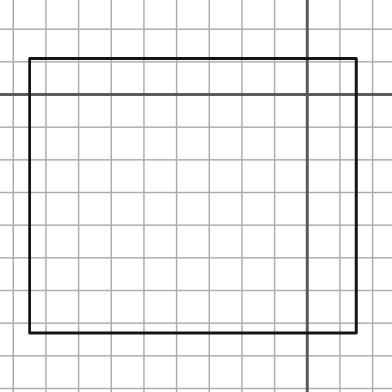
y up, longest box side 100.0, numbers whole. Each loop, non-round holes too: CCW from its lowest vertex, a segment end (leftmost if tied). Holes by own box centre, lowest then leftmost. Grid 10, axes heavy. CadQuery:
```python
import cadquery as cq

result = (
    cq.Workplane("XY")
    .moveTo(-85.0, -73.0)
    .lineTo(15.0, -73.0)
    .lineTo(15.0, 11.0)
    .lineTo(-85.0, 11.0)
    .close()
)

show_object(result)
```